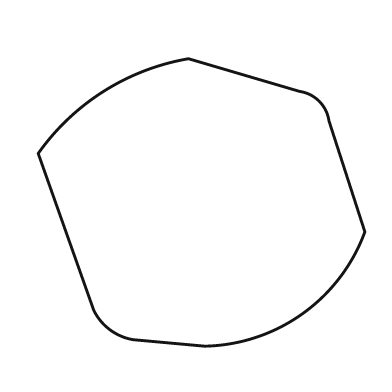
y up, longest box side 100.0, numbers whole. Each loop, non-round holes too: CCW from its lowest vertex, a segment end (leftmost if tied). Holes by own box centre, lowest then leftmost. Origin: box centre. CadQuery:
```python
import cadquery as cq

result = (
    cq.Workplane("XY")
    .moveTo(1.0, -44.0)
    .threePointArc((31.0, -34.0), (50.0, -9.0))
    .lineTo(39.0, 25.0)
    .threePointArc((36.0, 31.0), (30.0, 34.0))
    .lineTo(-4.0, 44.0)
    .threePointArc((-30.0, 34.0), (-50.0, 15.0))
    .lineTo(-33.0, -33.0)
    .threePointArc((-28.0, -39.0), (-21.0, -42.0))
    .close()
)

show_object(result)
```